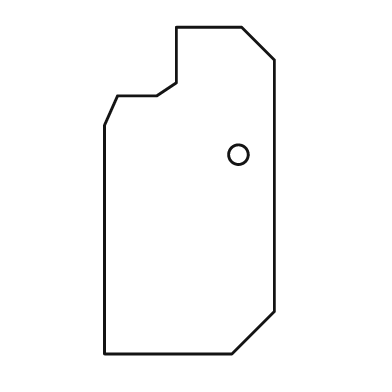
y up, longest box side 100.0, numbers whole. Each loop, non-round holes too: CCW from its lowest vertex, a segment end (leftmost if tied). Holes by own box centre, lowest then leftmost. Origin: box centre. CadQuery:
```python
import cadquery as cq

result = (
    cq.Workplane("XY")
    .moveTo(-26.0, -50.0)
    .lineTo(13.0, -50.0)
    .lineTo(26.0, -37.0)
    .lineTo(26.0, 40.0)
    .lineTo(16.0, 50.0)
    .lineTo(-4.0, 50.0)
    .lineTo(-4.0, 33.0)
    .lineTo(-10.0, 29.0)
    .lineTo(-22.0, 29.0)
    .lineTo(-26.0, 20.0)
    .close()
    .moveTo(15.0, 11.0)
    .circle(3.0)
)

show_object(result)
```